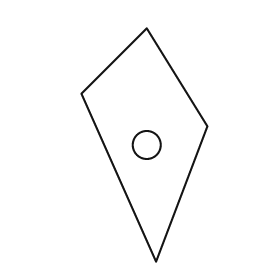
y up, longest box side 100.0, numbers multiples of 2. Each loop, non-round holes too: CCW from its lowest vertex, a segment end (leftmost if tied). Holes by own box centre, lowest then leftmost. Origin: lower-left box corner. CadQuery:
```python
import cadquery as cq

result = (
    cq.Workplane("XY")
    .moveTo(32.0, 0.0)
    .lineTo(54.0, 58.0)
    .lineTo(28.0, 100.0)
    .lineTo(0.0, 72.0)
    .close()
    .moveTo(28.0, 50.0)
    .circle(6.0)
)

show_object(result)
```